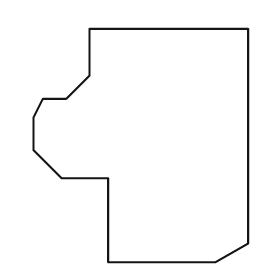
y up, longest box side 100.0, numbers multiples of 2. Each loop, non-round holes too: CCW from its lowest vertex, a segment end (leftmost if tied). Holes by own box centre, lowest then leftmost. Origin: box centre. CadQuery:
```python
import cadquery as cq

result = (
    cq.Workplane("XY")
    .moveTo(-14.0, -50.0)
    .lineTo(32.0, -50.0)
    .lineTo(46.0, -42.0)
    .lineTo(46.0, 50.0)
    .lineTo(-22.0, 50.0)
    .lineTo(-22.0, 30.0)
    .lineTo(-32.0, 20.0)
    .lineTo(-42.0, 20.0)
    .lineTo(-46.0, 12.0)
    .lineTo(-46.0, -2.0)
    .lineTo(-34.0, -14.0)
    .lineTo(-14.0, -14.0)
    .close()
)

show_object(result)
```